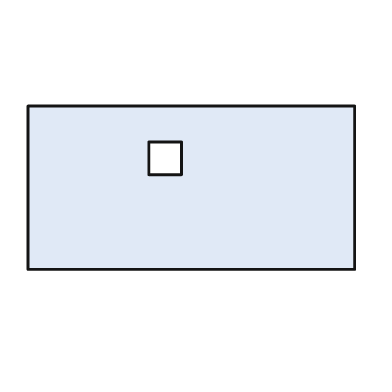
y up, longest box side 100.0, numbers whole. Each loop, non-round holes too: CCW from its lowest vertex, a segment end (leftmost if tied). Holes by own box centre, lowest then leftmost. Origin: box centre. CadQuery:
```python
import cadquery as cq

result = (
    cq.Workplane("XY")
    .moveTo(-50.0, -25.0)
    .lineTo(50.0, -25.0)
    .lineTo(50.0, 25.0)
    .lineTo(-50.0, 25.0)
    .close()
    .moveTo(-13.0, 4.0)
    .lineTo(-3.0, 4.0)
    .lineTo(-3.0, 14.0)
    .lineTo(-13.0, 14.0)
    .close()
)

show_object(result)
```